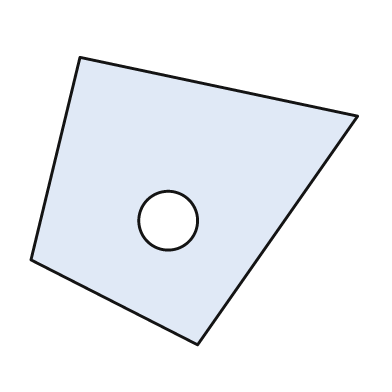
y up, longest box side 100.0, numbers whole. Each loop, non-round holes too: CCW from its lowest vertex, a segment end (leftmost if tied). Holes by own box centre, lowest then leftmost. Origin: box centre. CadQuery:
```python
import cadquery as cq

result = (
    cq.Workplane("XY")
    .moveTo(1.0, -44.0)
    .lineTo(50.0, 26.0)
    .lineTo(-35.0, 44.0)
    .lineTo(-50.0, -18.0)
    .close()
    .moveTo(-8.0, -6.0)
    .circle(9.0)
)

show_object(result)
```